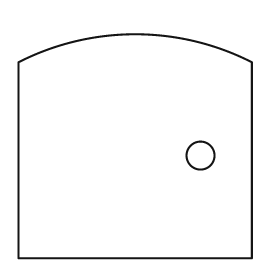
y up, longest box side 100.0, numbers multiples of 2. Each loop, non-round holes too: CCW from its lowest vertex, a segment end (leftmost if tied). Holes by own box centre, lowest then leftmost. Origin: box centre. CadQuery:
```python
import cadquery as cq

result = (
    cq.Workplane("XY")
    .moveTo(-50.0, -48.0)
    .lineTo(50.0, -48.0)
    .lineTo(50.0, 36.0)
    .threePointArc((0.0, 48.0), (-50.0, 36.0))
    .close()
    .moveTo(28.0, -4.0)
    .circle(6.0)
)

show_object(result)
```